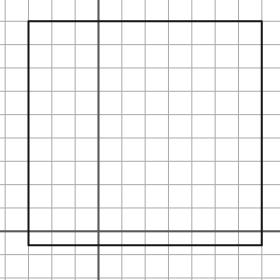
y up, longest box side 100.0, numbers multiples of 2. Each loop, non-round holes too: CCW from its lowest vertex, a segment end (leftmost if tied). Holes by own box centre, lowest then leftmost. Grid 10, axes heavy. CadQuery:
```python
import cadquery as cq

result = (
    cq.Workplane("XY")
    .moveTo(-30.0, -6.0)
    .lineTo(70.0, -6.0)
    .lineTo(70.0, 90.0)
    .lineTo(-30.0, 90.0)
    .close()
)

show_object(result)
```